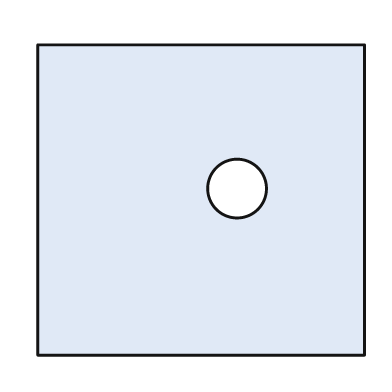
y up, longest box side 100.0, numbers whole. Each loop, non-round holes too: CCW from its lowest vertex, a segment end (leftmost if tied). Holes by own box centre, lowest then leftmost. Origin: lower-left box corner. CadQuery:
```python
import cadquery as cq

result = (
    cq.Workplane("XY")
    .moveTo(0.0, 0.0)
    .lineTo(100.0, 0.0)
    .lineTo(100.0, 95.0)
    .lineTo(0.0, 95.0)
    .close()
    .moveTo(61.0, 51.0)
    .circle(9.0)
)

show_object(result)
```